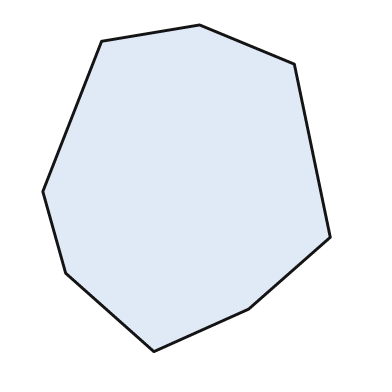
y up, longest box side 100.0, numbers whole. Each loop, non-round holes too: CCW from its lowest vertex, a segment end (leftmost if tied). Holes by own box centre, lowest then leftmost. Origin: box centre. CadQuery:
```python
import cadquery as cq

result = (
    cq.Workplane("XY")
    .moveTo(-10.0, -50.0)
    .lineTo(19.0, -37.0)
    .lineTo(44.0, -15.0)
    .lineTo(33.0, 38.0)
    .lineTo(4.0, 50.0)
    .lineTo(-26.0, 45.0)
    .lineTo(-44.0, -1.0)
    .lineTo(-37.0, -26.0)
    .close()
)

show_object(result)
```